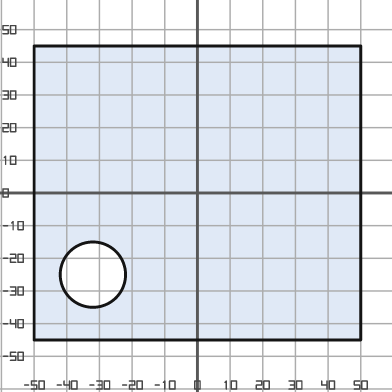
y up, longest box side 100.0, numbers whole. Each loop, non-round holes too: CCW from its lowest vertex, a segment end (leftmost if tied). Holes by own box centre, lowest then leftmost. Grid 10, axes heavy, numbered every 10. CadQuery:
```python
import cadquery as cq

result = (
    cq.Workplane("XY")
    .moveTo(-50.0, -45.0)
    .lineTo(50.0, -45.0)
    .lineTo(50.0, 45.0)
    .lineTo(-50.0, 45.0)
    .close()
    .moveTo(-32.0, -25.0)
    .circle(10.0)
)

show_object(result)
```